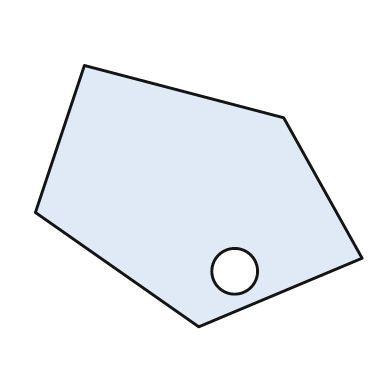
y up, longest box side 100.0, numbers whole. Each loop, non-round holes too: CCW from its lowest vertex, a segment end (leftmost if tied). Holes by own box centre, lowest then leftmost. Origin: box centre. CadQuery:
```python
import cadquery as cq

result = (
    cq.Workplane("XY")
    .moveTo(0.0, -40.0)
    .lineTo(50.0, -19.0)
    .lineTo(26.0, 24.0)
    .lineTo(-35.0, 40.0)
    .lineTo(-50.0, -5.0)
    .close()
    .moveTo(11.0, -23.0)
    .circle(7.0)
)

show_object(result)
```